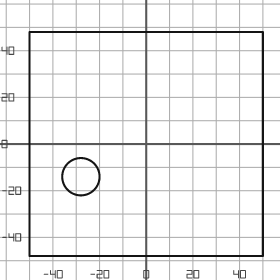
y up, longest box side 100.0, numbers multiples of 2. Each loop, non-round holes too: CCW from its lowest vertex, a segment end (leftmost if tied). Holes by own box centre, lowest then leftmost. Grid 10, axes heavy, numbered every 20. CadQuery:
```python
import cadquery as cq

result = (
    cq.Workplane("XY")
    .moveTo(-50.0, -48.0)
    .lineTo(50.0, -48.0)
    .lineTo(50.0, 48.0)
    .lineTo(-50.0, 48.0)
    .close()
    .moveTo(-28.0, -14.0)
    .circle(8.0)
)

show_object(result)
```